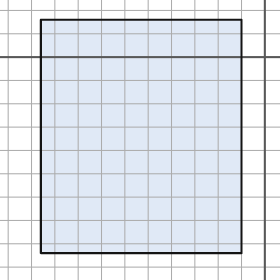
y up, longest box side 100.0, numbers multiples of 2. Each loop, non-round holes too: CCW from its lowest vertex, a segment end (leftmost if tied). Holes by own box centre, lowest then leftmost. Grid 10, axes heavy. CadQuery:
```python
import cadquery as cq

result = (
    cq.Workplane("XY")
    .moveTo(-96.0, -84.0)
    .lineTo(-10.0, -84.0)
    .lineTo(-10.0, 16.0)
    .lineTo(-96.0, 16.0)
    .close()
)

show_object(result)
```